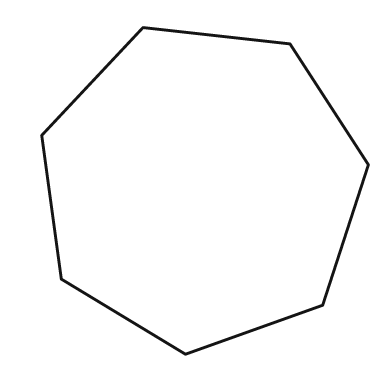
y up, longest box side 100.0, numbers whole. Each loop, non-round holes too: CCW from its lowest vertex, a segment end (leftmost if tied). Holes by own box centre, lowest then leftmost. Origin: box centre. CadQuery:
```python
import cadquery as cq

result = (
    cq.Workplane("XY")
    .moveTo(-6.0, -50.0)
    .lineTo(36.0, -35.0)
    .lineTo(50.0, 8.0)
    .lineTo(26.0, 45.0)
    .lineTo(-19.0, 50.0)
    .lineTo(-50.0, 17.0)
    .lineTo(-44.0, -27.0)
    .close()
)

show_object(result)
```